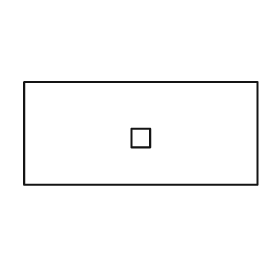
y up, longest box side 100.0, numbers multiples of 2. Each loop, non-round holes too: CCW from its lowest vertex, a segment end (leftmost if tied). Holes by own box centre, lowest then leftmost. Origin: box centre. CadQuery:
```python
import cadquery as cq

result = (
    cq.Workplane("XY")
    .moveTo(-50.0, -22.0)
    .lineTo(50.0, -22.0)
    .lineTo(50.0, 22.0)
    .lineTo(-50.0, 22.0)
    .close()
    .moveTo(-4.0, -6.0)
    .lineTo(4.0, -6.0)
    .lineTo(4.0, 2.0)
    .lineTo(-4.0, 2.0)
    .close()
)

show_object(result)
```